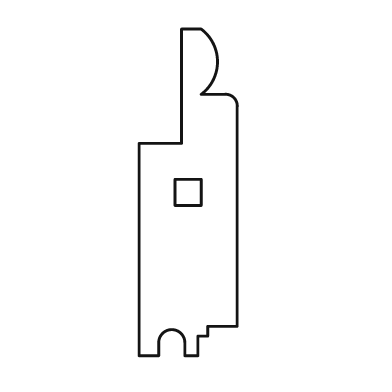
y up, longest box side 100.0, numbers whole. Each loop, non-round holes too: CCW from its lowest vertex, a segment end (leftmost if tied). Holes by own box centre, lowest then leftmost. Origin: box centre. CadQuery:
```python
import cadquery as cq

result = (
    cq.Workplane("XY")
    .moveTo(-15.0, -50.0)
    .lineTo(-9.0, -50.0)
    .lineTo(-9.0, -46.0)
    .threePointArc((-5.0, -42.0), (-1.0, -46.0))
    .lineTo(-1.0, -50.0)
    .lineTo(3.0, -50.0)
    .lineTo(3.0, -44.0)
    .lineTo(6.0, -44.0)
    .lineTo(6.0, -41.0)
    .lineTo(15.0, -41.0)
    .lineTo(15.0, 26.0)
    .threePointArc((14.0, 29.0), (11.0, 30.0))
    .lineTo(4.0, 30.0)
    .threePointArc((9.0, 40.0), (4.0, 50.0))
    .lineTo(-2.0, 50.0)
    .lineTo(-2.0, 15.0)
    .lineTo(-15.0, 15.0)
    .close()
    .moveTo(-4.0, -4.0)
    .lineTo(4.0, -4.0)
    .lineTo(4.0, 4.0)
    .lineTo(-4.0, 4.0)
    .close()
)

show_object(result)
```